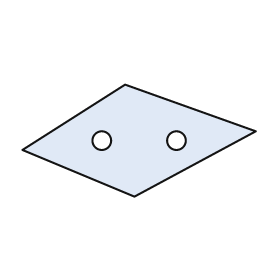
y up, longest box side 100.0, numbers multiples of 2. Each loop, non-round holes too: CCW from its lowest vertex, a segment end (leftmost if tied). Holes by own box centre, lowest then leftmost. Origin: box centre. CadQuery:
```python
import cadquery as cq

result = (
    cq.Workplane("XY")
    .moveTo(-2.0, -24.0)
    .lineTo(50.0, 4.0)
    .lineTo(-6.0, 24.0)
    .lineTo(-50.0, -4.0)
    .close()
    .moveTo(-16.0, 0.0)
    .circle(4.0)
    .moveTo(16.0, 0.0)
    .circle(4.0)
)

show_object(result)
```